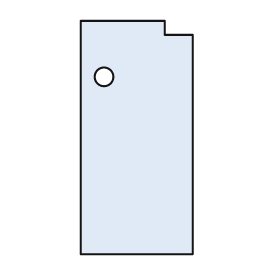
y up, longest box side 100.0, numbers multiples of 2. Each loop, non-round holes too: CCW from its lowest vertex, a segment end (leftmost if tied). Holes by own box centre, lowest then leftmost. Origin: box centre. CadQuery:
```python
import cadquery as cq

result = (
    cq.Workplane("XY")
    .moveTo(-24.0, -50.0)
    .lineTo(24.0, -50.0)
    .lineTo(24.0, 44.0)
    .lineTo(12.0, 44.0)
    .lineTo(12.0, 50.0)
    .lineTo(-24.0, 50.0)
    .close()
    .moveTo(-14.0, 26.0)
    .circle(4.0)
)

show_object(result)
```